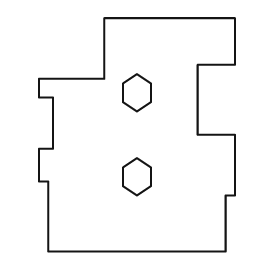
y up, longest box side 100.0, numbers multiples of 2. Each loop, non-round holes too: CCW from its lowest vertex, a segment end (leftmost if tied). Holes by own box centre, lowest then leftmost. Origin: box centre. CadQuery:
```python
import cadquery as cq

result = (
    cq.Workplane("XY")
    .moveTo(-38.0, -50.0)
    .lineTo(38.0, -50.0)
    .lineTo(38.0, -26.0)
    .lineTo(42.0, -26.0)
    .lineTo(42.0, 0.0)
    .lineTo(26.0, 0.0)
    .lineTo(26.0, 30.0)
    .lineTo(42.0, 30.0)
    .lineTo(42.0, 50.0)
    .lineTo(-14.0, 50.0)
    .lineTo(-14.0, 24.0)
    .lineTo(-42.0, 24.0)
    .lineTo(-42.0, 16.0)
    .lineTo(-36.0, 16.0)
    .lineTo(-36.0, -6.0)
    .lineTo(-42.0, -6.0)
    .lineTo(-42.0, -20.0)
    .lineTo(-38.0, -20.0)
    .close()
    .moveTo(0.0, -26.0)
    .lineTo(6.0, -22.0)
    .lineTo(6.0, -14.0)
    .lineTo(0.0, -10.0)
    .lineTo(-6.0, -14.0)
    .lineTo(-6.0, -22.0)
    .close()
    .moveTo(0.0, 10.0)
    .lineTo(6.0, 14.0)
    .lineTo(6.0, 22.0)
    .lineTo(0.0, 26.0)
    .lineTo(-6.0, 22.0)
    .lineTo(-6.0, 14.0)
    .close()
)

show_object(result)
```